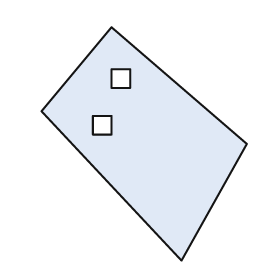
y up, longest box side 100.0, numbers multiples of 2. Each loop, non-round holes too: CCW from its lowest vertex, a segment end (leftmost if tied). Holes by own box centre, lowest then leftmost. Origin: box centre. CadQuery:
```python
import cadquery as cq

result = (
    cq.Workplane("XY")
    .moveTo(16.0, -50.0)
    .lineTo(44.0, 0.0)
    .lineTo(-14.0, 50.0)
    .lineTo(-44.0, 14.0)
    .close()
    .moveTo(-22.0, 4.0)
    .lineTo(-14.0, 4.0)
    .lineTo(-14.0, 12.0)
    .lineTo(-22.0, 12.0)
    .close()
    .moveTo(-14.0, 24.0)
    .lineTo(-6.0, 24.0)
    .lineTo(-6.0, 32.0)
    .lineTo(-14.0, 32.0)
    .close()
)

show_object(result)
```